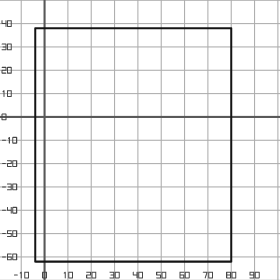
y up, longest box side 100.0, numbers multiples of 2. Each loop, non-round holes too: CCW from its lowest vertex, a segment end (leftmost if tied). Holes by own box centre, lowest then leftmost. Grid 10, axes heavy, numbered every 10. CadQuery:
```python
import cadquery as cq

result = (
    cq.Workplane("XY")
    .moveTo(-4.0, -62.0)
    .lineTo(80.0, -62.0)
    .lineTo(80.0, 38.0)
    .lineTo(-4.0, 38.0)
    .close()
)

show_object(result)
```